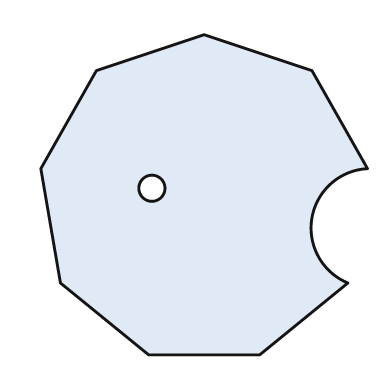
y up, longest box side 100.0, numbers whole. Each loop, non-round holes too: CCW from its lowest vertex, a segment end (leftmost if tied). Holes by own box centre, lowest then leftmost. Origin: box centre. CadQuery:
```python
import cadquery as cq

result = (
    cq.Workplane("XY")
    .moveTo(-17.0, -49.0)
    .lineTo(17.0, -49.0)
    .lineTo(44.0, -27.0)
    .threePointArc((33.0, -7.0), (50.0, 8.0))
    .lineTo(33.0, 38.0)
    .lineTo(0.0, 49.0)
    .lineTo(-33.0, 38.0)
    .lineTo(-50.0, 8.0)
    .lineTo(-44.0, -27.0)
    .close()
    .moveTo(-16.0, 2.0)
    .circle(4.0)
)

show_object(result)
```